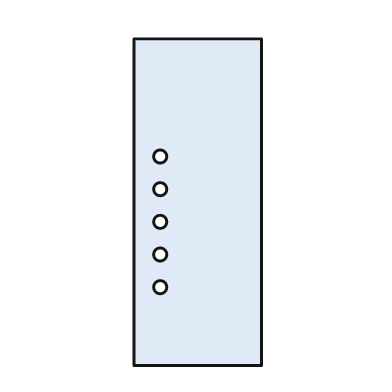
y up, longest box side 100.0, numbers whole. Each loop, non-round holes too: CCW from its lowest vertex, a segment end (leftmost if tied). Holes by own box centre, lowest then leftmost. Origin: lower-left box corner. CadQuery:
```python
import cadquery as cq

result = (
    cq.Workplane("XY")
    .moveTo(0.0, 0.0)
    .lineTo(39.0, 0.0)
    .lineTo(39.0, 100.0)
    .lineTo(0.0, 100.0)
    .close()
    .moveTo(8.0, 24.0)
    .circle(2.0)
    .moveTo(8.0, 34.0)
    .circle(2.0)
    .moveTo(8.0, 44.0)
    .circle(2.0)
    .moveTo(8.0, 54.0)
    .circle(2.0)
    .moveTo(8.0, 64.0)
    .circle(2.0)
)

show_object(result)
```